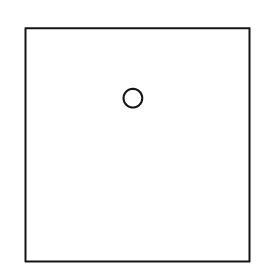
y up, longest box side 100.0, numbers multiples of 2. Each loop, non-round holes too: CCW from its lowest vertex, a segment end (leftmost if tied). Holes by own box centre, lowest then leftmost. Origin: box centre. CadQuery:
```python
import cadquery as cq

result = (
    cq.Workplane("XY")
    .moveTo(-48.0, -50.0)
    .lineTo(48.0, -50.0)
    .lineTo(48.0, 50.0)
    .lineTo(-48.0, 50.0)
    .close()
    .moveTo(-2.0, 20.0)
    .circle(4.0)
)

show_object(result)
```